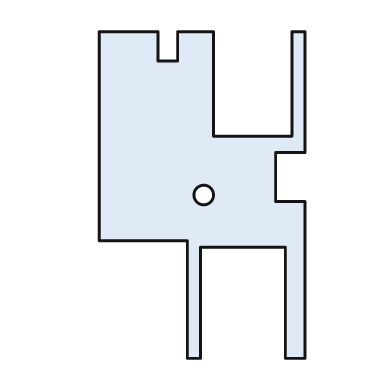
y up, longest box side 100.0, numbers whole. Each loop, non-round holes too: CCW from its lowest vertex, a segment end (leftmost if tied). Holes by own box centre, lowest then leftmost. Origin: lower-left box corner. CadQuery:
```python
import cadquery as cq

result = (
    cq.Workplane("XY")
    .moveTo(27.0, 0.0)
    .lineTo(31.0, 0.0)
    .lineTo(31.0, 34.0)
    .lineTo(57.0, 34.0)
    .lineTo(57.0, 0.0)
    .lineTo(63.0, 0.0)
    .lineTo(63.0, 48.0)
    .lineTo(54.0, 48.0)
    .lineTo(54.0, 63.0)
    .lineTo(63.0, 63.0)
    .lineTo(63.0, 100.0)
    .lineTo(59.0, 100.0)
    .lineTo(59.0, 68.0)
    .lineTo(35.0, 68.0)
    .lineTo(35.0, 100.0)
    .lineTo(24.0, 100.0)
    .lineTo(24.0, 91.0)
    .lineTo(18.0, 91.0)
    .lineTo(18.0, 100.0)
    .lineTo(0.0, 100.0)
    .lineTo(0.0, 36.0)
    .lineTo(27.0, 36.0)
    .close()
    .moveTo(32.0, 50.0)
    .circle(3.0)
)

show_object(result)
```